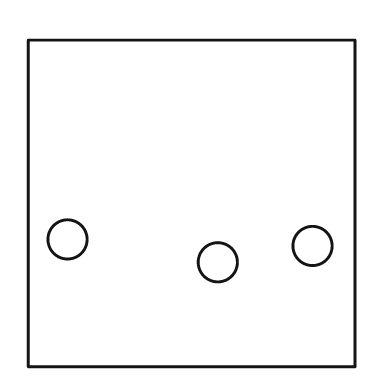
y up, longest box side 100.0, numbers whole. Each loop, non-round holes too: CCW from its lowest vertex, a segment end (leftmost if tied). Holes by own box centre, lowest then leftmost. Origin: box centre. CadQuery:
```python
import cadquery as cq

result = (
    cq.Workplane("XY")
    .moveTo(-50.0, -50.0)
    .lineTo(50.0, -50.0)
    .lineTo(50.0, 50.0)
    .lineTo(-50.0, 50.0)
    .close()
    .moveTo(8.0, -18.0)
    .circle(6.0)
    .moveTo(37.0, -13.0)
    .circle(6.0)
    .moveTo(-38.0, -11.0)
    .circle(6.0)
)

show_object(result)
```